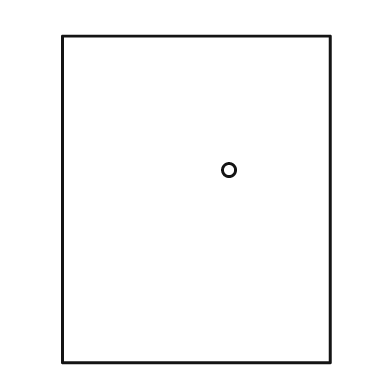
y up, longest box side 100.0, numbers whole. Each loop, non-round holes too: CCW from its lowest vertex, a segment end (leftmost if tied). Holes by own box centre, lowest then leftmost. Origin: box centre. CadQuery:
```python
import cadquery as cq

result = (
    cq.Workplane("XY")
    .moveTo(-41.0, -50.0)
    .lineTo(41.0, -50.0)
    .lineTo(41.0, 50.0)
    .lineTo(-41.0, 50.0)
    .close()
    .moveTo(10.0, 9.0)
    .circle(2.0)
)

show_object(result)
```